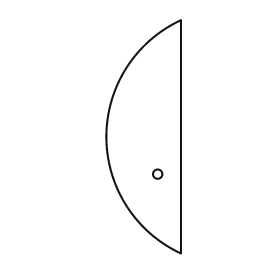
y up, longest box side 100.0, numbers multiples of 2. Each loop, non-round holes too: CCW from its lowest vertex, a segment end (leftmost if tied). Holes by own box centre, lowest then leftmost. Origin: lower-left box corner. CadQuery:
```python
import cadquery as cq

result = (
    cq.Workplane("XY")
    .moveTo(32.0, 0.0)
    .lineTo(32.0, 100.0)
    .threePointArc((0.0, 50.0), (32.0, 0.0))
    .close()
    .moveTo(22.0, 34.0)
    .circle(2.0)
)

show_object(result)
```